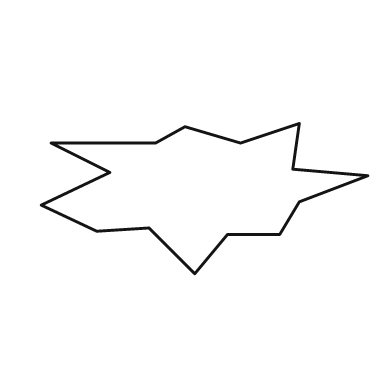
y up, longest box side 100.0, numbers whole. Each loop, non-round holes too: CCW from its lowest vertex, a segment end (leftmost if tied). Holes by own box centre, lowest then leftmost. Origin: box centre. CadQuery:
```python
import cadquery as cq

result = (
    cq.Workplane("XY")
    .moveTo(-3.0, -23.0)
    .lineTo(7.0, -11.0)
    .lineTo(23.0, -11.0)
    .lineTo(29.0, -1.0)
    .lineTo(50.0, 7.0)
    .lineTo(27.0, 9.0)
    .lineTo(29.0, 23.0)
    .lineTo(11.0, 17.0)
    .lineTo(-6.0, 22.0)
    .lineTo(-15.0, 17.0)
    .lineTo(-47.0, 17.0)
    .lineTo(-29.0, 8.0)
    .lineTo(-50.0, -2.0)
    .lineTo(-33.0, -10.0)
    .lineTo(-17.0, -9.0)
    .close()
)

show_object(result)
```